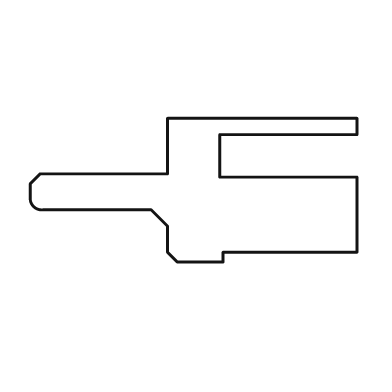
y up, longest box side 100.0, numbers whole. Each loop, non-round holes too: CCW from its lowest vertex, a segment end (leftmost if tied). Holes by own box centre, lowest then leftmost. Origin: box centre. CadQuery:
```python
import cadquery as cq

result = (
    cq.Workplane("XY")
    .moveTo(-5.0, -22.0)
    .lineTo(9.0, -22.0)
    .lineTo(9.0, -19.0)
    .lineTo(50.0, -19.0)
    .lineTo(50.0, 4.0)
    .lineTo(8.0, 4.0)
    .lineTo(8.0, 17.0)
    .lineTo(50.0, 17.0)
    .lineTo(50.0, 22.0)
    .lineTo(-8.0, 22.0)
    .lineTo(-8.0, 5.0)
    .lineTo(-47.0, 5.0)
    .lineTo(-50.0, 2.0)
    .lineTo(-50.0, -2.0)
    .threePointArc((-49.0, -5.0), (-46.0, -6.0))
    .lineTo(-13.0, -6.0)
    .lineTo(-8.0, -11.0)
    .lineTo(-8.0, -19.0)
    .close()
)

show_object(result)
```